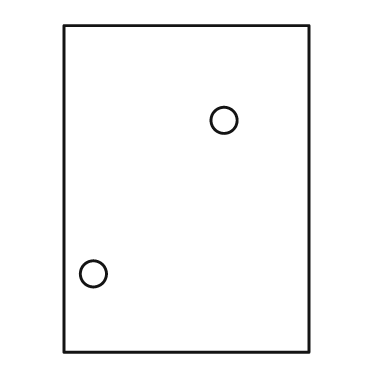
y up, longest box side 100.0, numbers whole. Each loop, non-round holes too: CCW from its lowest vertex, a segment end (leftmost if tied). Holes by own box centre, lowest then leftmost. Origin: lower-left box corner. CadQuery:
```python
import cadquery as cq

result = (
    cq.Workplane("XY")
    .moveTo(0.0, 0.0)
    .lineTo(75.0, 0.0)
    .lineTo(75.0, 100.0)
    .lineTo(0.0, 100.0)
    .close()
    .moveTo(9.0, 24.0)
    .circle(4.0)
    .moveTo(49.0, 71.0)
    .circle(4.0)
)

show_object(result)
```